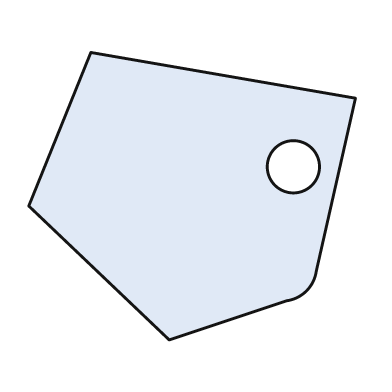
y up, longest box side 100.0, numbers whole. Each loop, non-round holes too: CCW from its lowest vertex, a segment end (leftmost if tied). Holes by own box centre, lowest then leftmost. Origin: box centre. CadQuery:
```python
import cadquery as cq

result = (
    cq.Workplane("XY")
    .moveTo(-7.0, -44.0)
    .lineTo(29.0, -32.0)
    .threePointArc((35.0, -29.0), (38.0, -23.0))
    .lineTo(50.0, 30.0)
    .lineTo(-31.0, 44.0)
    .lineTo(-50.0, -3.0)
    .close()
    .moveTo(31.0, 9.0)
    .circle(8.0)
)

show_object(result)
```